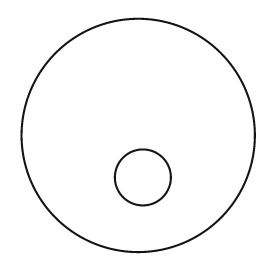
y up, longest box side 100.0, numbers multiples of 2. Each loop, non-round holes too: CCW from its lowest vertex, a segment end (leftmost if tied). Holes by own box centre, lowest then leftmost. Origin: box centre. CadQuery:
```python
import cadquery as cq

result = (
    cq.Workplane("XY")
    .moveTo(0.0, 0.0)
    .circle(50.0)
    .moveTo(2.0, -18.0)
    .circle(12.0)
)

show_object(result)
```